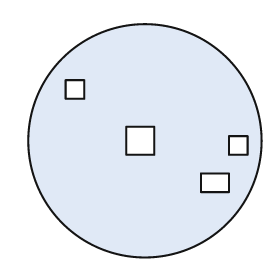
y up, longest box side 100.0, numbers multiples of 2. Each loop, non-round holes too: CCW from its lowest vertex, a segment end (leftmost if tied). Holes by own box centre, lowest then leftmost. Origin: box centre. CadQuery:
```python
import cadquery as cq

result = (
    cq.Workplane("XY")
    .moveTo(0.0, 0.0)
    .circle(50.0)
    .moveTo(24.0, -22.0)
    .lineTo(36.0, -22.0)
    .lineTo(36.0, -14.0)
    .lineTo(24.0, -14.0)
    .close()
    .moveTo(36.0, -6.0)
    .lineTo(44.0, -6.0)
    .lineTo(44.0, 2.0)
    .lineTo(36.0, 2.0)
    .close()
    .moveTo(-8.0, -6.0)
    .lineTo(4.0, -6.0)
    .lineTo(4.0, 6.0)
    .lineTo(-8.0, 6.0)
    .close()
    .moveTo(-34.0, 18.0)
    .lineTo(-26.0, 18.0)
    .lineTo(-26.0, 26.0)
    .lineTo(-34.0, 26.0)
    .close()
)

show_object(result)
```